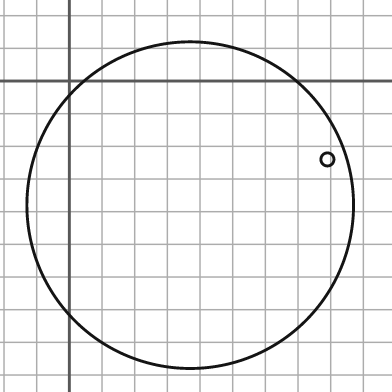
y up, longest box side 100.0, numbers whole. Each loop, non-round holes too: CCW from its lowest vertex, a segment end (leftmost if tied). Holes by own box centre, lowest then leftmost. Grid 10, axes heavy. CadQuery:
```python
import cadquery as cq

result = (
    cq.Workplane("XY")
    .moveTo(37.0, -38.0)
    .circle(50.0)
    .moveTo(79.0, -24.0)
    .circle(2.0)
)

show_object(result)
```